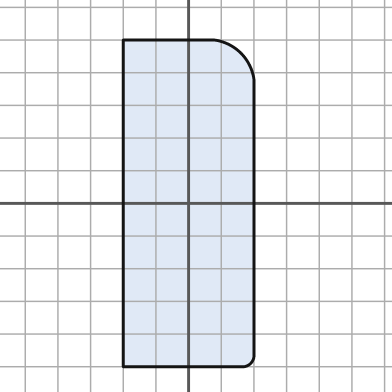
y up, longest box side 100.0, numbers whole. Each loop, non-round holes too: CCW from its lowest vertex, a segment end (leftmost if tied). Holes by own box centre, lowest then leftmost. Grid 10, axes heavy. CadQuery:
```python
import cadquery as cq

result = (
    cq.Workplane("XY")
    .moveTo(-20.0, -50.0)
    .lineTo(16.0, -50.0)
    .threePointArc((19.0, -49.0), (20.0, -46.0))
    .lineTo(20.0, 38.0)
    .threePointArc((16.0, 46.0), (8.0, 50.0))
    .lineTo(-20.0, 50.0)
    .close()
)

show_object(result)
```